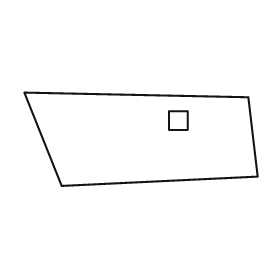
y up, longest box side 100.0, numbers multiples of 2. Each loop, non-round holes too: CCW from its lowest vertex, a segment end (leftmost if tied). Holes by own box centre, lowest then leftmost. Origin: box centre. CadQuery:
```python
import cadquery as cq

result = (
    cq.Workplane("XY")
    .moveTo(-34.0, -20.0)
    .lineTo(50.0, -16.0)
    .lineTo(46.0, 18.0)
    .lineTo(-50.0, 20.0)
    .close()
    .moveTo(12.0, 4.0)
    .lineTo(20.0, 4.0)
    .lineTo(20.0, 12.0)
    .lineTo(12.0, 12.0)
    .close()
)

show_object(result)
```